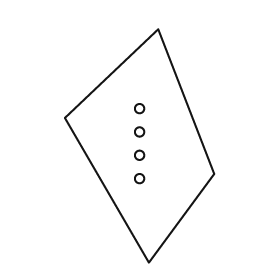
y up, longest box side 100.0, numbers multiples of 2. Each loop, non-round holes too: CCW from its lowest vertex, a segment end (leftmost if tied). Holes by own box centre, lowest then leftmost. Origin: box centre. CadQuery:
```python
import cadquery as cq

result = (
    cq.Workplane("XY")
    .moveTo(4.0, -50.0)
    .lineTo(32.0, -12.0)
    .lineTo(8.0, 50.0)
    .lineTo(-32.0, 12.0)
    .close()
    .moveTo(0.0, -14.0)
    .circle(2.0)
    .moveTo(0.0, -4.0)
    .circle(2.0)
    .moveTo(0.0, 6.0)
    .circle(2.0)
    .moveTo(0.0, 16.0)
    .circle(2.0)
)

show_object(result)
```